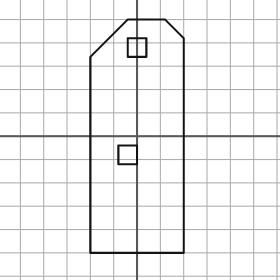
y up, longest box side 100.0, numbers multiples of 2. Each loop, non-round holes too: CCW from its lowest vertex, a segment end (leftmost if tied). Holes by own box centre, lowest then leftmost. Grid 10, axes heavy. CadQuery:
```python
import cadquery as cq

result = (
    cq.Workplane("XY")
    .moveTo(-20.0, -50.0)
    .lineTo(20.0, -50.0)
    .lineTo(20.0, 42.0)
    .lineTo(12.0, 50.0)
    .lineTo(-4.0, 50.0)
    .lineTo(-20.0, 34.0)
    .close()
    .moveTo(-8.0, -12.0)
    .lineTo(0.0, -12.0)
    .lineTo(0.0, -4.0)
    .lineTo(-8.0, -4.0)
    .close()
    .moveTo(-4.0, 34.0)
    .lineTo(4.0, 34.0)
    .lineTo(4.0, 42.0)
    .lineTo(-4.0, 42.0)
    .close()
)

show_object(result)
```